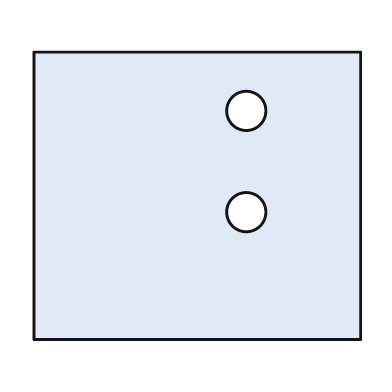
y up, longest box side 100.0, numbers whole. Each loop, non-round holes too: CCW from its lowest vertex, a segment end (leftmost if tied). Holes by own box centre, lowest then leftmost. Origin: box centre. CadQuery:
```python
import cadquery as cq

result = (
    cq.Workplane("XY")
    .moveTo(-50.0, -44.0)
    .lineTo(50.0, -44.0)
    .lineTo(50.0, 44.0)
    .lineTo(-50.0, 44.0)
    .close()
    .moveTo(15.0, -5.0)
    .circle(6.0)
    .moveTo(15.0, 26.0)
    .circle(6.0)
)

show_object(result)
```